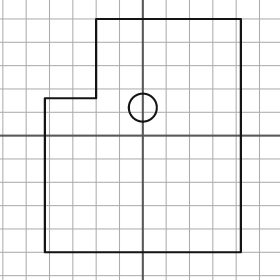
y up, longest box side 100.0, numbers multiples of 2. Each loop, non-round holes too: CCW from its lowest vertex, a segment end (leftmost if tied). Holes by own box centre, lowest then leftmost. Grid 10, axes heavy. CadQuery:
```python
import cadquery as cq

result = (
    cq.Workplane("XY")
    .moveTo(-42.0, -50.0)
    .lineTo(42.0, -50.0)
    .lineTo(42.0, 50.0)
    .lineTo(-20.0, 50.0)
    .lineTo(-20.0, 16.0)
    .lineTo(-42.0, 16.0)
    .close()
    .moveTo(0.0, 12.0)
    .circle(6.0)
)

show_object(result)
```